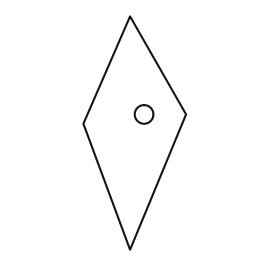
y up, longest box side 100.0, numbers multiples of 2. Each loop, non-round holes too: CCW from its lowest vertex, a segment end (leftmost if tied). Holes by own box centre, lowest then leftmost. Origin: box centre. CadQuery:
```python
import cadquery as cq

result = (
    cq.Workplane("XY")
    .moveTo(-2.0, -50.0)
    .lineTo(22.0, 8.0)
    .lineTo(-2.0, 50.0)
    .lineTo(-22.0, 4.0)
    .close()
    .moveTo(4.0, 8.0)
    .circle(4.0)
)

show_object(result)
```